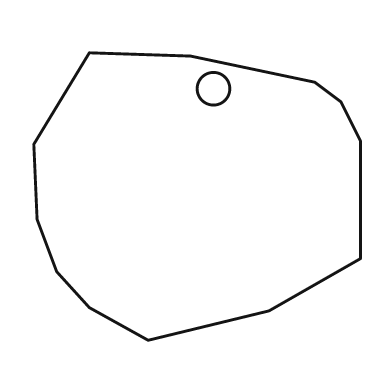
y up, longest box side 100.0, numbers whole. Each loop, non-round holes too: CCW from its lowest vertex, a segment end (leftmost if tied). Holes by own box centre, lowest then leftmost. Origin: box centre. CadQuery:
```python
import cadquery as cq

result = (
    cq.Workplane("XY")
    .moveTo(-15.0, -44.0)
    .lineTo(22.0, -35.0)
    .lineTo(50.0, -19.0)
    .lineTo(50.0, 17.0)
    .lineTo(44.0, 29.0)
    .lineTo(36.0, 35.0)
    .lineTo(-2.0, 43.0)
    .lineTo(-33.0, 44.0)
    .lineTo(-50.0, 16.0)
    .lineTo(-49.0, -7.0)
    .lineTo(-43.0, -23.0)
    .lineTo(-33.0, -34.0)
    .close()
    .moveTo(5.0, 33.0)
    .circle(5.0)
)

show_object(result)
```